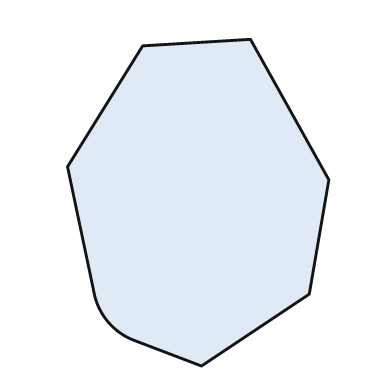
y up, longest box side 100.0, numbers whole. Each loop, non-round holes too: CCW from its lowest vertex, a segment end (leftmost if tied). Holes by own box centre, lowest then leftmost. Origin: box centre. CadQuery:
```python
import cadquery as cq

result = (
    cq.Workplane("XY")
    .moveTo(1.0, -50.0)
    .lineTo(34.0, -28.0)
    .lineTo(40.0, 7.0)
    .lineTo(16.0, 50.0)
    .lineTo(-17.0, 48.0)
    .lineTo(-40.0, 11.0)
    .lineTo(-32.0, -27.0)
    .threePointArc((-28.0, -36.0), (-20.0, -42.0))
    .close()
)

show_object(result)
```